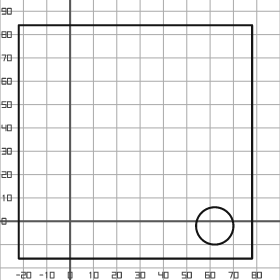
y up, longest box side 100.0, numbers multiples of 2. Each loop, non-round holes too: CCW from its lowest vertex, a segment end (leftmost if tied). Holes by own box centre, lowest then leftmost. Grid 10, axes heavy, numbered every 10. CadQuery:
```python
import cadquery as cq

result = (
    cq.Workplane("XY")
    .moveTo(-22.0, -16.0)
    .lineTo(78.0, -16.0)
    .lineTo(78.0, 84.0)
    .lineTo(-22.0, 84.0)
    .close()
    .moveTo(62.0, -2.0)
    .circle(8.0)
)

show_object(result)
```